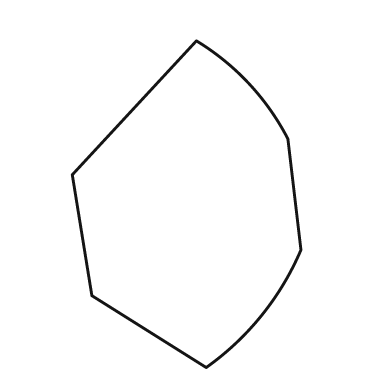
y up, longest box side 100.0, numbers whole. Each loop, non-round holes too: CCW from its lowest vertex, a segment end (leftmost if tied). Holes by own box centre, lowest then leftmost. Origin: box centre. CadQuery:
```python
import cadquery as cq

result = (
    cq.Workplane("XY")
    .moveTo(6.0, -50.0)
    .threePointArc((23.0, -34.0), (35.0, -14.0))
    .lineTo(31.0, 20.0)
    .threePointArc((19.0, 37.0), (3.0, 50.0))
    .lineTo(-35.0, 9.0)
    .lineTo(-29.0, -28.0)
    .close()
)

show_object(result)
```